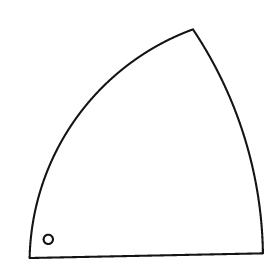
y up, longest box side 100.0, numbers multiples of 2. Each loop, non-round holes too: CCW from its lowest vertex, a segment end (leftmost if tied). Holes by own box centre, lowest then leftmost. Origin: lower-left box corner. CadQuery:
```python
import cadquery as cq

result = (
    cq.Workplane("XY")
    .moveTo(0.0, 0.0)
    .lineTo(100.0, 2.0)
    .threePointArc((92.0, 52.0), (70.0, 98.0))
    .threePointArc((20.0, 60.0), (0.0, 0.0))
    .close()
    .moveTo(8.0, 8.0)
    .circle(2.0)
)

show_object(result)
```